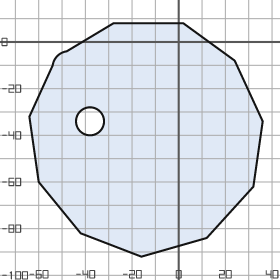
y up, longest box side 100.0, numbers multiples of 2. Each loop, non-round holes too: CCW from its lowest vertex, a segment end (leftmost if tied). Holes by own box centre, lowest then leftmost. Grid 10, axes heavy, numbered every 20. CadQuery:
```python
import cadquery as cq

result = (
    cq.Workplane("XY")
    .moveTo(-16.0, -92.0)
    .lineTo(12.0, -84.0)
    .lineTo(32.0, -62.0)
    .lineTo(36.0, -34.0)
    .lineTo(24.0, -8.0)
    .lineTo(2.0, 8.0)
    .lineTo(-28.0, 8.0)
    .lineTo(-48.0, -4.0)
    .threePointArc((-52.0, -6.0), (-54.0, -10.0))
    .lineTo(-64.0, -32.0)
    .lineTo(-60.0, -60.0)
    .lineTo(-42.0, -82.0)
    .close()
    .moveTo(-38.0, -34.0)
    .circle(6.0)
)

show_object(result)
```